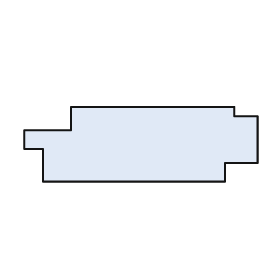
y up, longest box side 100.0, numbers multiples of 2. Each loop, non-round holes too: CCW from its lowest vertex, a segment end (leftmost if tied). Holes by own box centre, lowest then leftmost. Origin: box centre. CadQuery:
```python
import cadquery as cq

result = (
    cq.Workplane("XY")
    .moveTo(-42.0, -16.0)
    .lineTo(36.0, -16.0)
    .lineTo(36.0, -8.0)
    .lineTo(50.0, -8.0)
    .lineTo(50.0, 12.0)
    .lineTo(40.0, 12.0)
    .lineTo(40.0, 16.0)
    .lineTo(-30.0, 16.0)
    .lineTo(-30.0, 6.0)
    .lineTo(-50.0, 6.0)
    .lineTo(-50.0, -2.0)
    .lineTo(-42.0, -2.0)
    .close()
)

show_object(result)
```